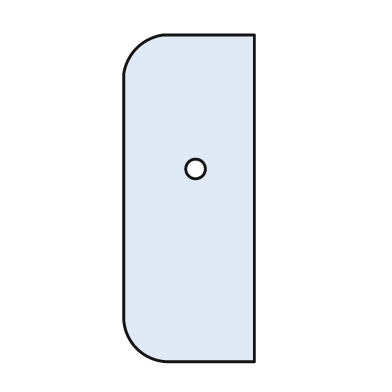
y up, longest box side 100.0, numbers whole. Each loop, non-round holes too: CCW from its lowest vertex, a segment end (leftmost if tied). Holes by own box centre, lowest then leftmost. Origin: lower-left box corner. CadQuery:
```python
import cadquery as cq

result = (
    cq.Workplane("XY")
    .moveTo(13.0, 0.0)
    .lineTo(40.0, 0.0)
    .lineTo(40.0, 100.0)
    .lineTo(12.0, 100.0)
    .threePointArc((4.0, 96.0), (0.0, 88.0))
    .lineTo(0.0, 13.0)
    .threePointArc((4.0, 4.0), (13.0, 0.0))
    .close()
    .moveTo(22.0, 59.0)
    .circle(3.0)
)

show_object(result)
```